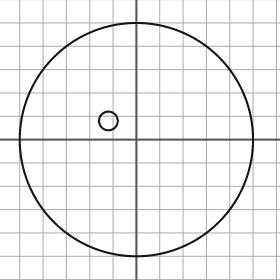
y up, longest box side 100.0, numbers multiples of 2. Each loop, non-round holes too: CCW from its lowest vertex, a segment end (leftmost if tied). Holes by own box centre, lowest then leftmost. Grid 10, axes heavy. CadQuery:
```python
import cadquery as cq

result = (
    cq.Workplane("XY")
    .moveTo(0.0, 0.0)
    .circle(50.0)
    .moveTo(-12.0, 8.0)
    .circle(4.0)
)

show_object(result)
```